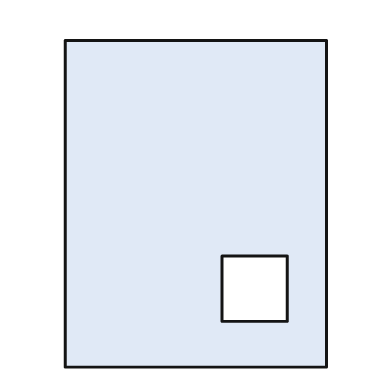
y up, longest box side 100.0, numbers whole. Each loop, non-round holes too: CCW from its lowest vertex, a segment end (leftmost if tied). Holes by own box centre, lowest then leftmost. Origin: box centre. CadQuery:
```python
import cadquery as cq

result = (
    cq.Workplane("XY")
    .moveTo(-40.0, -50.0)
    .lineTo(40.0, -50.0)
    .lineTo(40.0, 50.0)
    .lineTo(-40.0, 50.0)
    .close()
    .moveTo(8.0, -36.0)
    .lineTo(28.0, -36.0)
    .lineTo(28.0, -16.0)
    .lineTo(8.0, -16.0)
    .close()
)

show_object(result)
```